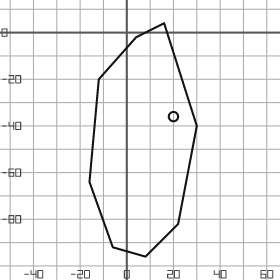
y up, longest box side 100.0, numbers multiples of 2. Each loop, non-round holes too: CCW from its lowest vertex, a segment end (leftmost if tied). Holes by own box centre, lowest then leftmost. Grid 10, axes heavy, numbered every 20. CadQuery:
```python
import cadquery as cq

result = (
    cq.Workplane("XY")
    .moveTo(8.0, -96.0)
    .lineTo(22.0, -82.0)
    .lineTo(30.0, -40.0)
    .lineTo(16.0, 4.0)
    .lineTo(4.0, -2.0)
    .lineTo(-12.0, -20.0)
    .lineTo(-16.0, -64.0)
    .lineTo(-6.0, -92.0)
    .close()
    .moveTo(20.0, -36.0)
    .circle(2.0)
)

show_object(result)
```